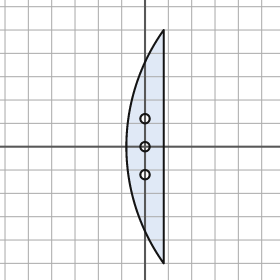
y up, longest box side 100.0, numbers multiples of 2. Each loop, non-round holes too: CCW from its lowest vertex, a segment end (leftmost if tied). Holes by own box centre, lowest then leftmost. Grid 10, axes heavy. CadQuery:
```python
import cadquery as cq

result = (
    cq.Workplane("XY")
    .moveTo(8.0, -50.0)
    .lineTo(8.0, 50.0)
    .threePointArc((-8.0, 0.0), (8.0, -50.0))
    .close()
    .moveTo(0.0, -12.0)
    .circle(2.0)
    .moveTo(0.0, 0.0)
    .circle(2.0)
    .moveTo(0.0, 12.0)
    .circle(2.0)
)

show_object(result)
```